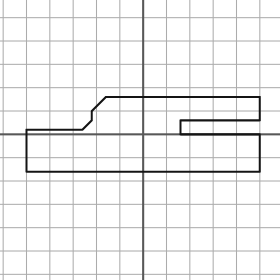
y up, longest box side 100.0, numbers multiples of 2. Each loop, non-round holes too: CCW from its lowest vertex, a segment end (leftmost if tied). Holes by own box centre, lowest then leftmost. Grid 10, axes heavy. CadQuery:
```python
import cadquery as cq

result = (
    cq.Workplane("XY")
    .moveTo(-50.0, -16.0)
    .lineTo(50.0, -16.0)
    .lineTo(50.0, 0.0)
    .lineTo(16.0, 0.0)
    .lineTo(16.0, 6.0)
    .lineTo(50.0, 6.0)
    .lineTo(50.0, 16.0)
    .lineTo(-16.0, 16.0)
    .lineTo(-22.0, 10.0)
    .lineTo(-22.0, 6.0)
    .lineTo(-26.0, 2.0)
    .lineTo(-50.0, 2.0)
    .close()
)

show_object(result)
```